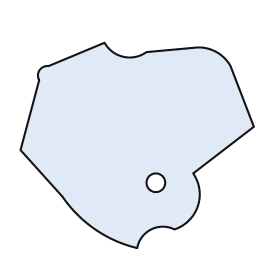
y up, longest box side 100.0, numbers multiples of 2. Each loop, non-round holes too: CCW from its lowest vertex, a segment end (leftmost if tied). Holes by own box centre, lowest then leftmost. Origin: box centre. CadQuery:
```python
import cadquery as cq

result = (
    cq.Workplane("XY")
    .moveTo(0.0, -44.0)
    .threePointArc((6.0, -36.0), (16.0, -36.0))
    .threePointArc((26.0, -26.0), (24.0, -12.0))
    .lineTo(50.0, 8.0)
    .lineTo(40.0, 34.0)
    .threePointArc((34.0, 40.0), (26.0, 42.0))
    .lineTo(4.0, 40.0)
    .threePointArc((-6.0, 38.0), (-14.0, 44.0))
    .lineTo(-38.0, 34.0)
    .threePointArc((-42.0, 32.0), (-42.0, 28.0))
    .lineTo(-50.0, -2.0)
    .lineTo(-32.0, -22.0)
    .threePointArc((-18.0, -36.0), (0.0, -44.0))
    .close()
    .moveTo(8.0, -16.0)
    .circle(4.0)
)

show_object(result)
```